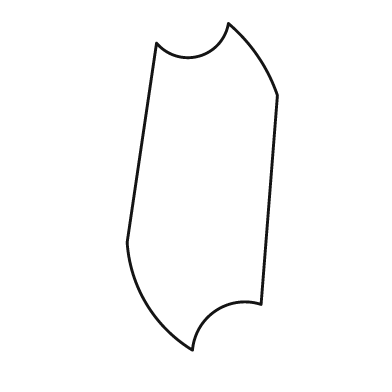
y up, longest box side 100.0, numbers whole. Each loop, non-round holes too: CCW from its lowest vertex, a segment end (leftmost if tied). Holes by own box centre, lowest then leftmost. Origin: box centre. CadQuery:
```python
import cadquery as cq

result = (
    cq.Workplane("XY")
    .moveTo(-3.0, -50.0)
    .threePointArc((4.0, -38.0), (18.0, -36.0))
    .lineTo(23.0, 28.0)
    .threePointArc((17.0, 40.0), (8.0, 50.0))
    .threePointArc((-1.0, 40.0), (-14.0, 44.0))
    .lineTo(-23.0, -17.0)
    .threePointArc((-17.0, -36.0), (-3.0, -50.0))
    .close()
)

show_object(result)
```